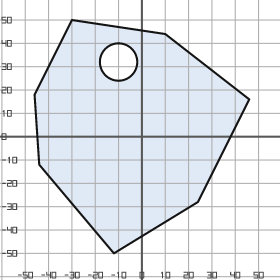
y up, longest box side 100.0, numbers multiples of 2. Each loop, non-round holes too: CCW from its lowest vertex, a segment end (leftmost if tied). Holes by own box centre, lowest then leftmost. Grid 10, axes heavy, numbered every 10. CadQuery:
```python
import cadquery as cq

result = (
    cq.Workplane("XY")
    .moveTo(-12.0, -50.0)
    .lineTo(24.0, -28.0)
    .lineTo(46.0, 16.0)
    .lineTo(10.0, 44.0)
    .lineTo(-30.0, 50.0)
    .lineTo(-46.0, 18.0)
    .lineTo(-44.0, -12.0)
    .close()
    .moveTo(-10.0, 32.0)
    .circle(8.0)
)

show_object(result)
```